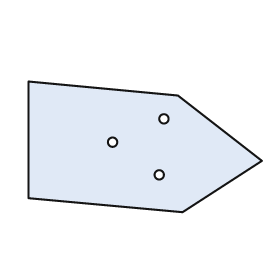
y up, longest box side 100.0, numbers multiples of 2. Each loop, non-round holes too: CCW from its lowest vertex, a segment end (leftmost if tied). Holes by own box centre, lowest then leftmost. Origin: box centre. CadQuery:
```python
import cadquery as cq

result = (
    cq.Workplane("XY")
    .moveTo(16.0, -28.0)
    .lineTo(50.0, -6.0)
    .lineTo(14.0, 22.0)
    .lineTo(-50.0, 28.0)
    .lineTo(-50.0, -22.0)
    .close()
    .moveTo(6.0, -12.0)
    .circle(2.0)
    .moveTo(-14.0, 2.0)
    .circle(2.0)
    .moveTo(8.0, 12.0)
    .circle(2.0)
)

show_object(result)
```